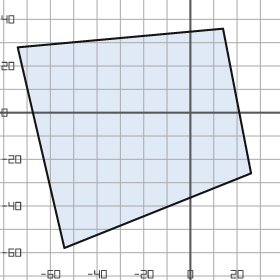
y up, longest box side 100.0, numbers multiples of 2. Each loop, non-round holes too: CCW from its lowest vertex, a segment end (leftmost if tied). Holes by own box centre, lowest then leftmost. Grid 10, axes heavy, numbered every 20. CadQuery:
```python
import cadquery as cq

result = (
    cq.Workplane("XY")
    .moveTo(-54.0, -58.0)
    .lineTo(26.0, -26.0)
    .lineTo(14.0, 36.0)
    .lineTo(-74.0, 28.0)
    .close()
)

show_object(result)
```